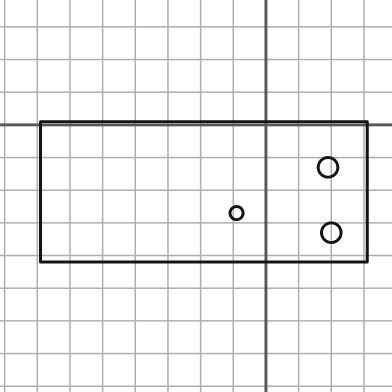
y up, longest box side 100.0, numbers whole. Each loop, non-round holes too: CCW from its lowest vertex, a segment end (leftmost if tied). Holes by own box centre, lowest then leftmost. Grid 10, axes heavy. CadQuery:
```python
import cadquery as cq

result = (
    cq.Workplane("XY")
    .moveTo(-69.0, -42.0)
    .lineTo(31.0, -42.0)
    .lineTo(31.0, 1.0)
    .lineTo(-69.0, 1.0)
    .close()
    .moveTo(20.0, -33.0)
    .circle(3.0)
    .moveTo(-9.0, -27.0)
    .circle(2.0)
    .moveTo(19.0, -13.0)
    .circle(3.0)
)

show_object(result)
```